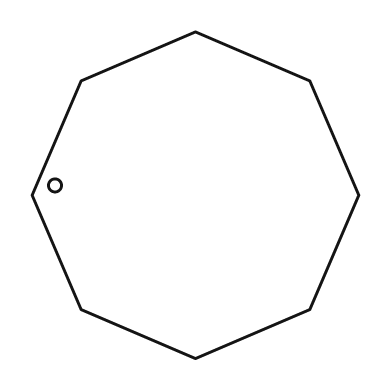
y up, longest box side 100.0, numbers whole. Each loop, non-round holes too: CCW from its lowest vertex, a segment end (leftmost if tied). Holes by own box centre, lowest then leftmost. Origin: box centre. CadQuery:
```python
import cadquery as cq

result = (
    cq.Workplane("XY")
    .moveTo(0.0, -50.0)
    .lineTo(35.0, -35.0)
    .lineTo(50.0, 0.0)
    .lineTo(35.0, 35.0)
    .lineTo(0.0, 50.0)
    .lineTo(-35.0, 35.0)
    .lineTo(-50.0, 0.0)
    .lineTo(-35.0, -35.0)
    .close()
    .moveTo(-43.0, 3.0)
    .circle(2.0)
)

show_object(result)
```